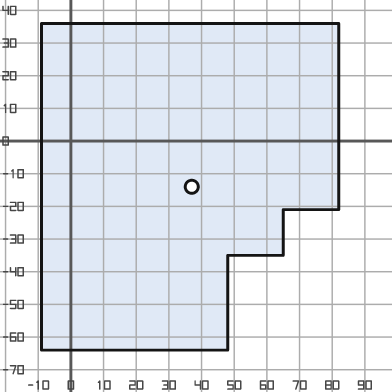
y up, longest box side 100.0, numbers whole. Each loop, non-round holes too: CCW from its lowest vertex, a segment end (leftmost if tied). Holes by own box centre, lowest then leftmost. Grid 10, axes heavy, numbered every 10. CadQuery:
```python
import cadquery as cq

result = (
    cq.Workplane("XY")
    .moveTo(-9.0, -64.0)
    .lineTo(48.0, -64.0)
    .lineTo(48.0, -35.0)
    .lineTo(65.0, -35.0)
    .lineTo(65.0, -21.0)
    .lineTo(82.0, -21.0)
    .lineTo(82.0, 36.0)
    .lineTo(-9.0, 36.0)
    .close()
    .moveTo(37.0, -14.0)
    .circle(2.0)
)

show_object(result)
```